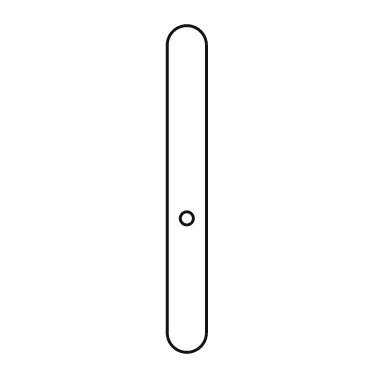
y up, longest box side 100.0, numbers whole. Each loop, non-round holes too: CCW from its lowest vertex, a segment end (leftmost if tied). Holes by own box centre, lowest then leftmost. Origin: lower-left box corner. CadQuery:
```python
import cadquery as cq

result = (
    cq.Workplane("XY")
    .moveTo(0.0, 6.0)
    .threePointArc((6.0, 0.0), (12.0, 6.0))
    .lineTo(12.0, 94.0)
    .threePointArc((6.0, 100.0), (0.0, 94.0))
    .close()
    .moveTo(6.0, 41.0)
    .circle(2.0)
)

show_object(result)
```